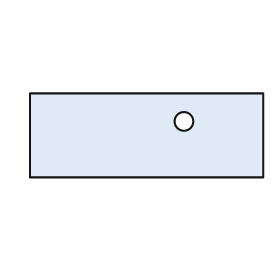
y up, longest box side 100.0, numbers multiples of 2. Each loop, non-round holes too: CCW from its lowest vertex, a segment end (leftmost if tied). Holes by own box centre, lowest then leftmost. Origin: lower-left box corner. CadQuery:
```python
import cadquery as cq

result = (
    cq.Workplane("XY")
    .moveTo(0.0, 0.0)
    .lineTo(100.0, 0.0)
    .lineTo(100.0, 36.0)
    .lineTo(0.0, 36.0)
    .close()
    .moveTo(66.0, 24.0)
    .circle(4.0)
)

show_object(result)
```